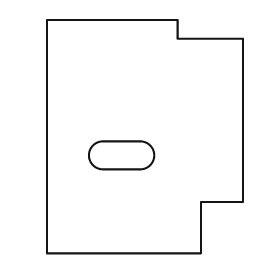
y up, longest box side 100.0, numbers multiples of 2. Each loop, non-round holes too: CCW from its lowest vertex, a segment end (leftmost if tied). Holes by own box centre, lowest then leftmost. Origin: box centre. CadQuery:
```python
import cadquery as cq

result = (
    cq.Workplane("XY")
    .moveTo(-42.0, -50.0)
    .lineTo(24.0, -50.0)
    .lineTo(24.0, -28.0)
    .lineTo(42.0, -28.0)
    .lineTo(42.0, 42.0)
    .lineTo(14.0, 42.0)
    .lineTo(14.0, 50.0)
    .lineTo(-42.0, 50.0)
    .close()
    .moveTo(-18.0, -14.0)
    .lineTo(-2.0, -14.0)
    .threePointArc((4.0, -8.0), (-2.0, -2.0))
    .lineTo(-18.0, -2.0)
    .threePointArc((-24.0, -8.0), (-18.0, -14.0))
    .close()
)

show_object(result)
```